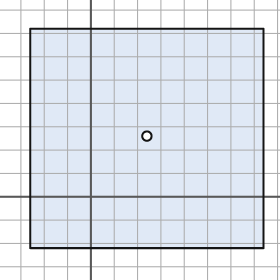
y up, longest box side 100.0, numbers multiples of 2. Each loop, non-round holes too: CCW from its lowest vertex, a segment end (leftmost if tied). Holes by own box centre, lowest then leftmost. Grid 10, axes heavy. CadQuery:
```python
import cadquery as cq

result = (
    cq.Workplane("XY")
    .moveTo(-26.0, -22.0)
    .lineTo(74.0, -22.0)
    .lineTo(74.0, 72.0)
    .lineTo(-26.0, 72.0)
    .close()
    .moveTo(24.0, 26.0)
    .circle(2.0)
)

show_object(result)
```